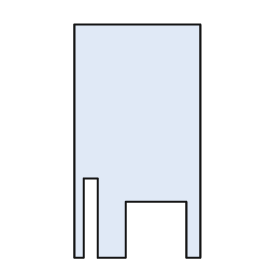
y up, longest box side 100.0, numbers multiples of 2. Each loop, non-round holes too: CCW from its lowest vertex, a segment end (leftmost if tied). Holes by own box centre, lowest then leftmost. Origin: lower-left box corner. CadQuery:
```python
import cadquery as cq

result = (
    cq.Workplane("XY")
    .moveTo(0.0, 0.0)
    .lineTo(4.0, 0.0)
    .lineTo(4.0, 34.0)
    .lineTo(10.0, 34.0)
    .lineTo(10.0, 0.0)
    .lineTo(22.0, 0.0)
    .lineTo(22.0, 24.0)
    .lineTo(48.0, 24.0)
    .lineTo(48.0, 0.0)
    .lineTo(54.0, 0.0)
    .lineTo(54.0, 100.0)
    .lineTo(0.0, 100.0)
    .close()
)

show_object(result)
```